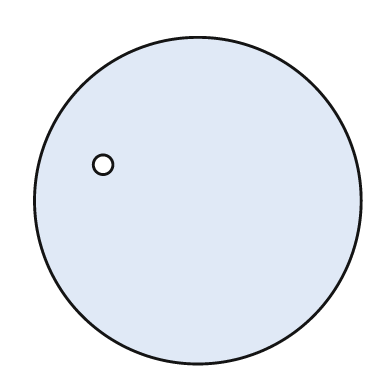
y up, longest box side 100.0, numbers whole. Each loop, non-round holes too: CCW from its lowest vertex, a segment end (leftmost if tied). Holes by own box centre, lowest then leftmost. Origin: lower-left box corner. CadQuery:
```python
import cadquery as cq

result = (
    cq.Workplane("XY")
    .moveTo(50.0, 50.0)
    .circle(50.0)
    .moveTo(21.0, 61.0)
    .circle(3.0)
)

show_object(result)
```